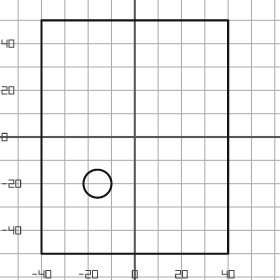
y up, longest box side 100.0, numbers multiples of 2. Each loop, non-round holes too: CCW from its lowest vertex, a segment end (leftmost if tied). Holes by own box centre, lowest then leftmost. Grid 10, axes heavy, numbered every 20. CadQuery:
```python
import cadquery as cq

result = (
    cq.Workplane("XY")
    .moveTo(-40.0, -50.0)
    .lineTo(40.0, -50.0)
    .lineTo(40.0, 50.0)
    .lineTo(-40.0, 50.0)
    .close()
    .moveTo(-16.0, -20.0)
    .circle(6.0)
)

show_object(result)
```